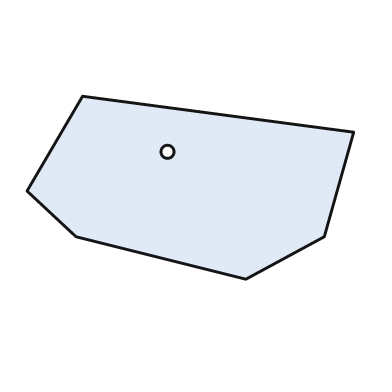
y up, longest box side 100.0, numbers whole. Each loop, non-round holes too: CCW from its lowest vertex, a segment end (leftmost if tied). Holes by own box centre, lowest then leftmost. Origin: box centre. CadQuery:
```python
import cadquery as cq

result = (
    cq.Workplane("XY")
    .moveTo(17.0, -28.0)
    .lineTo(41.0, -15.0)
    .lineTo(50.0, 17.0)
    .lineTo(-33.0, 28.0)
    .lineTo(-50.0, -1.0)
    .lineTo(-35.0, -15.0)
    .close()
    .moveTo(-7.0, 11.0)
    .circle(2.0)
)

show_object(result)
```